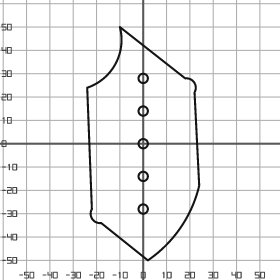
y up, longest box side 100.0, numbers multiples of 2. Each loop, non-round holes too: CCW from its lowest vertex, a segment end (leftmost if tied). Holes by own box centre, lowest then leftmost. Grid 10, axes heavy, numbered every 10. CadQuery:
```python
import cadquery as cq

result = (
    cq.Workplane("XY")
    .moveTo(2.0, -50.0)
    .threePointArc((16.0, -36.0), (24.0, -18.0))
    .lineTo(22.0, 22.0)
    .threePointArc((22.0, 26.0), (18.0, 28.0))
    .lineTo(-10.0, 50.0)
    .threePointArc((-12.0, 34.0), (-24.0, 24.0))
    .lineTo(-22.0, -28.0)
    .threePointArc((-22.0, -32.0), (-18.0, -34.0))
    .close()
    .moveTo(0.0, -28.0)
    .circle(2.0)
    .moveTo(0.0, -14.0)
    .circle(2.0)
    .moveTo(0.0, 0.0)
    .circle(2.0)
    .moveTo(0.0, 14.0)
    .circle(2.0)
    .moveTo(0.0, 28.0)
    .circle(2.0)
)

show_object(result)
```